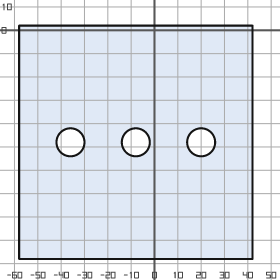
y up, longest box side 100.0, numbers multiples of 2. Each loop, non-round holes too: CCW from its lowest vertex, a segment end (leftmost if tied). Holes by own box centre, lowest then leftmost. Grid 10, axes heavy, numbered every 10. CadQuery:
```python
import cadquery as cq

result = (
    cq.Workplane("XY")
    .moveTo(-58.0, -98.0)
    .lineTo(42.0, -98.0)
    .lineTo(42.0, 2.0)
    .lineTo(-58.0, 2.0)
    .close()
    .moveTo(-36.0, -48.0)
    .circle(6.0)
    .moveTo(-8.0, -48.0)
    .circle(6.0)
    .moveTo(20.0, -48.0)
    .circle(6.0)
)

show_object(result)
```